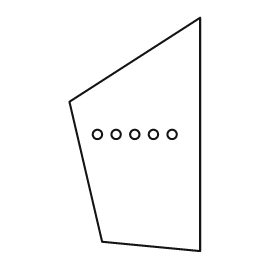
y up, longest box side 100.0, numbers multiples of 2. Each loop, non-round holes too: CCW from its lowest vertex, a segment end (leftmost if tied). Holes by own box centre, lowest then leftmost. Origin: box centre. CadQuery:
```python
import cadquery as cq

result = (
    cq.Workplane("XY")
    .moveTo(28.0, -50.0)
    .lineTo(28.0, 50.0)
    .lineTo(-28.0, 14.0)
    .lineTo(-14.0, -46.0)
    .close()
    .moveTo(-16.0, 0.0)
    .circle(2.0)
    .moveTo(-8.0, 0.0)
    .circle(2.0)
    .moveTo(0.0, 0.0)
    .circle(2.0)
    .moveTo(8.0, 0.0)
    .circle(2.0)
    .moveTo(16.0, 0.0)
    .circle(2.0)
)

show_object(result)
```